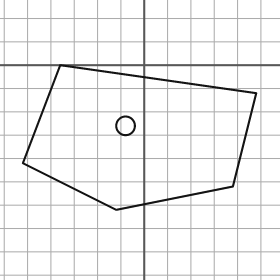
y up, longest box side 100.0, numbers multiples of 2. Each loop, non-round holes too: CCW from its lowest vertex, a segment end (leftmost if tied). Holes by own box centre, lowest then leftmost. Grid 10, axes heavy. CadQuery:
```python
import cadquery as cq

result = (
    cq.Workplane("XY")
    .moveTo(-12.0, -62.0)
    .lineTo(38.0, -52.0)
    .lineTo(48.0, -12.0)
    .lineTo(-36.0, 0.0)
    .lineTo(-52.0, -42.0)
    .close()
    .moveTo(-8.0, -26.0)
    .circle(4.0)
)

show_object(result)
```